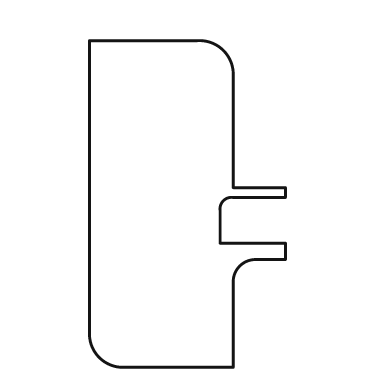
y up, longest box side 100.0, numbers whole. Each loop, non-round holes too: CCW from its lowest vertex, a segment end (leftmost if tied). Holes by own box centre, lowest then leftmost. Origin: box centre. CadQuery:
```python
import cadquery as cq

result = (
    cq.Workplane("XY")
    .moveTo(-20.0, -50.0)
    .lineTo(14.0, -50.0)
    .lineTo(14.0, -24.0)
    .threePointArc((16.0, -19.0), (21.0, -17.0))
    .lineTo(30.0, -17.0)
    .lineTo(30.0, -12.0)
    .lineTo(10.0, -12.0)
    .lineTo(10.0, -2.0)
    .threePointArc((11.0, 1.0), (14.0, 2.0))
    .lineTo(30.0, 2.0)
    .lineTo(30.0, 5.0)
    .lineTo(14.0, 5.0)
    .lineTo(14.0, 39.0)
    .threePointArc((11.0, 47.0), (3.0, 50.0))
    .lineTo(-30.0, 50.0)
    .lineTo(-30.0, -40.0)
    .threePointArc((-27.0, -47.0), (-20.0, -50.0))
    .close()
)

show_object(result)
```